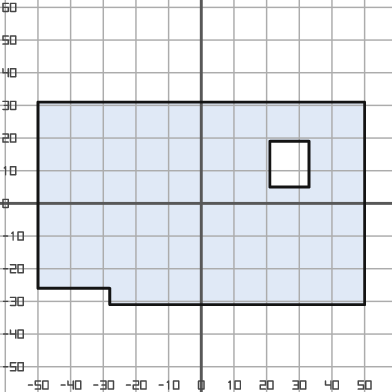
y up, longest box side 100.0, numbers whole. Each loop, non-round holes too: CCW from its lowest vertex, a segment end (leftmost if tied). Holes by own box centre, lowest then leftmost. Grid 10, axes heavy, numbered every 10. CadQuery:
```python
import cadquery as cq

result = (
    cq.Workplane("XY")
    .moveTo(-28.0, -31.0)
    .lineTo(50.0, -31.0)
    .lineTo(50.0, 31.0)
    .lineTo(-50.0, 31.0)
    .lineTo(-50.0, -26.0)
    .lineTo(-28.0, -26.0)
    .close()
    .moveTo(21.0, 5.0)
    .lineTo(33.0, 5.0)
    .lineTo(33.0, 19.0)
    .lineTo(21.0, 19.0)
    .close()
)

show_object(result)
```